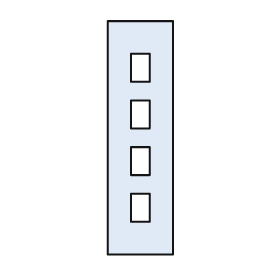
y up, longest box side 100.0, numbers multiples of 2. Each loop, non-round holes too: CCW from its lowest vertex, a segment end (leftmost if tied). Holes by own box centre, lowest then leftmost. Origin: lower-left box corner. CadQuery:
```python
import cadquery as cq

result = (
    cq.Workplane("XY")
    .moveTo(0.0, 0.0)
    .lineTo(28.0, 0.0)
    .lineTo(28.0, 100.0)
    .lineTo(0.0, 100.0)
    .close()
    .moveTo(10.0, 14.0)
    .lineTo(18.0, 14.0)
    .lineTo(18.0, 26.0)
    .lineTo(10.0, 26.0)
    .close()
    .moveTo(10.0, 34.0)
    .lineTo(18.0, 34.0)
    .lineTo(18.0, 46.0)
    .lineTo(10.0, 46.0)
    .close()
    .moveTo(10.0, 54.0)
    .lineTo(18.0, 54.0)
    .lineTo(18.0, 66.0)
    .lineTo(10.0, 66.0)
    .close()
    .moveTo(10.0, 74.0)
    .lineTo(18.0, 74.0)
    .lineTo(18.0, 86.0)
    .lineTo(10.0, 86.0)
    .close()
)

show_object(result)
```